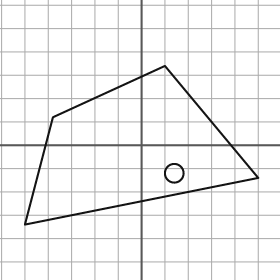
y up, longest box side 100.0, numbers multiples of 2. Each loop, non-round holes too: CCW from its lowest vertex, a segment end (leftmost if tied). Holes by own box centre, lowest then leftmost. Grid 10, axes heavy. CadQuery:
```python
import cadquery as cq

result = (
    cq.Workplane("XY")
    .moveTo(-50.0, -34.0)
    .lineTo(50.0, -14.0)
    .lineTo(10.0, 34.0)
    .lineTo(-38.0, 12.0)
    .close()
    .moveTo(14.0, -12.0)
    .circle(4.0)
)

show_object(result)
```